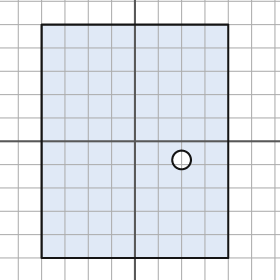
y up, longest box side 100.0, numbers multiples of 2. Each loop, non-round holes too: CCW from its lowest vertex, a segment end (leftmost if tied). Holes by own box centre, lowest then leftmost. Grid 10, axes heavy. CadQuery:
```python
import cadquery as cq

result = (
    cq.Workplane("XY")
    .moveTo(-40.0, -50.0)
    .lineTo(40.0, -50.0)
    .lineTo(40.0, 50.0)
    .lineTo(-40.0, 50.0)
    .close()
    .moveTo(20.0, -8.0)
    .circle(4.0)
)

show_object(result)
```